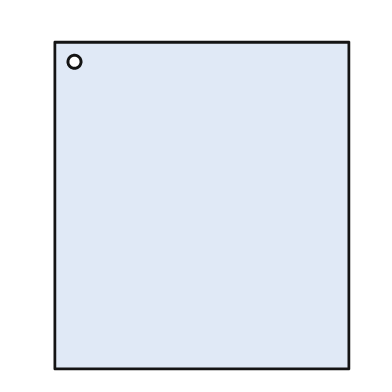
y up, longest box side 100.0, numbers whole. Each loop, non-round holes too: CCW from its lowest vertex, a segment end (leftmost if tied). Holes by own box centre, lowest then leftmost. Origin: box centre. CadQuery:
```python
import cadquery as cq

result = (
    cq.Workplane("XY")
    .moveTo(-45.0, -50.0)
    .lineTo(45.0, -50.0)
    .lineTo(45.0, 50.0)
    .lineTo(-45.0, 50.0)
    .close()
    .moveTo(-39.0, 44.0)
    .circle(2.0)
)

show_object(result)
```